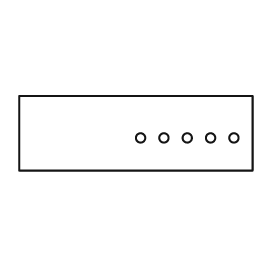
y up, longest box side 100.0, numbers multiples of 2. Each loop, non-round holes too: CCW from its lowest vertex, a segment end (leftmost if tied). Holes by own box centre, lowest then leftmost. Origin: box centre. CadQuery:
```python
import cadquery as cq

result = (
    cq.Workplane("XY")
    .moveTo(-50.0, -16.0)
    .lineTo(50.0, -16.0)
    .lineTo(50.0, 16.0)
    .lineTo(-50.0, 16.0)
    .close()
    .moveTo(2.0, -2.0)
    .circle(2.0)
    .moveTo(12.0, -2.0)
    .circle(2.0)
    .moveTo(22.0, -2.0)
    .circle(2.0)
    .moveTo(32.0, -2.0)
    .circle(2.0)
    .moveTo(42.0, -2.0)
    .circle(2.0)
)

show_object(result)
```